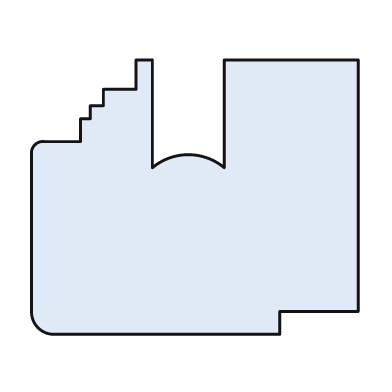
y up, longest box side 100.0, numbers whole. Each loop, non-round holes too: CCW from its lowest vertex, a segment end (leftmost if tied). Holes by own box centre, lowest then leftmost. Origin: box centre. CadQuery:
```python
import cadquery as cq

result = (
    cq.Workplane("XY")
    .moveTo(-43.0, -42.0)
    .lineTo(26.0, -42.0)
    .lineTo(26.0, -35.0)
    .lineTo(50.0, -35.0)
    .lineTo(50.0, 42.0)
    .lineTo(9.0, 42.0)
    .lineTo(9.0, 9.0)
    .threePointArc((-2.0, 13.0), (-13.0, 9.0))
    .lineTo(-13.0, 42.0)
    .lineTo(-18.0, 42.0)
    .lineTo(-18.0, 33.0)
    .lineTo(-28.0, 33.0)
    .lineTo(-28.0, 28.0)
    .lineTo(-32.0, 28.0)
    .lineTo(-32.0, 24.0)
    .lineTo(-35.0, 24.0)
    .lineTo(-35.0, 17.0)
    .lineTo(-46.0, 17.0)
    .threePointArc((-49.0, 16.0), (-50.0, 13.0))
    .lineTo(-50.0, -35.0)
    .threePointArc((-48.0, -40.0), (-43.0, -42.0))
    .close()
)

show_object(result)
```